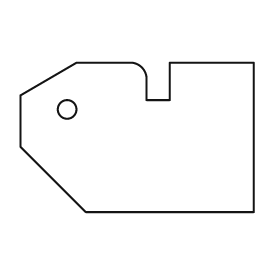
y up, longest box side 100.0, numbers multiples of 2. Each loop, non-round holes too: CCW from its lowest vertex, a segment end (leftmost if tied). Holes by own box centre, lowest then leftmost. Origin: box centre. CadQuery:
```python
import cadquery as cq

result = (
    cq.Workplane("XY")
    .moveTo(-22.0, -32.0)
    .lineTo(50.0, -32.0)
    .lineTo(50.0, 32.0)
    .lineTo(14.0, 32.0)
    .lineTo(14.0, 16.0)
    .lineTo(4.0, 16.0)
    .lineTo(4.0, 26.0)
    .threePointArc((2.0, 30.0), (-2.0, 32.0))
    .lineTo(-26.0, 32.0)
    .lineTo(-50.0, 18.0)
    .lineTo(-50.0, -4.0)
    .close()
    .moveTo(-30.0, 12.0)
    .circle(4.0)
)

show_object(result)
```